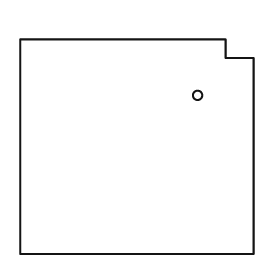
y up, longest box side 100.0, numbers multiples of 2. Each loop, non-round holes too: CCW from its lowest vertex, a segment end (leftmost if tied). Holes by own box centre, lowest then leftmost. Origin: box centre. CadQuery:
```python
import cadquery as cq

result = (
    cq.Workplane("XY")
    .moveTo(-50.0, -46.0)
    .lineTo(50.0, -46.0)
    .lineTo(50.0, 38.0)
    .lineTo(38.0, 38.0)
    .lineTo(38.0, 46.0)
    .lineTo(-50.0, 46.0)
    .close()
    .moveTo(26.0, 22.0)
    .circle(2.0)
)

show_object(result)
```